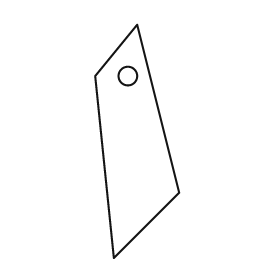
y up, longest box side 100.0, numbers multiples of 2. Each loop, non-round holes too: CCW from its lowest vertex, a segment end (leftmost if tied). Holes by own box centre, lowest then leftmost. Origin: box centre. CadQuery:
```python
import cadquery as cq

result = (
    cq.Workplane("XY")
    .moveTo(-10.0, -50.0)
    .lineTo(18.0, -22.0)
    .lineTo(0.0, 50.0)
    .lineTo(-18.0, 28.0)
    .close()
    .moveTo(-4.0, 28.0)
    .circle(4.0)
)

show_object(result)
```